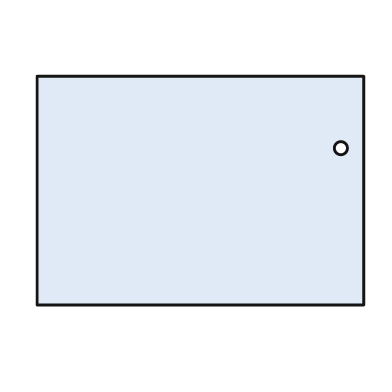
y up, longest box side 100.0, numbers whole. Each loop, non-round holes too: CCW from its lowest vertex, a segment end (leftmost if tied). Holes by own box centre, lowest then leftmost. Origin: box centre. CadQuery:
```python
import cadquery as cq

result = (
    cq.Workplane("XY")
    .moveTo(-50.0, -35.0)
    .lineTo(50.0, -35.0)
    .lineTo(50.0, 35.0)
    .lineTo(-50.0, 35.0)
    .close()
    .moveTo(43.0, 13.0)
    .circle(2.0)
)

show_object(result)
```